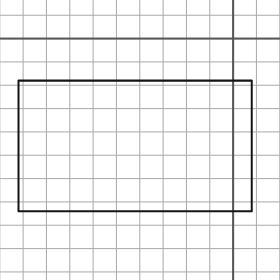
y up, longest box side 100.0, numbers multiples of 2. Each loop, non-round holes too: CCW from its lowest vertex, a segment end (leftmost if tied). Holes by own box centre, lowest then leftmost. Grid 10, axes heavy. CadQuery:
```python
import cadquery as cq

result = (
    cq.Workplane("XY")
    .moveTo(-92.0, -74.0)
    .lineTo(8.0, -74.0)
    .lineTo(8.0, -18.0)
    .lineTo(-92.0, -18.0)
    .close()
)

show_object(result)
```